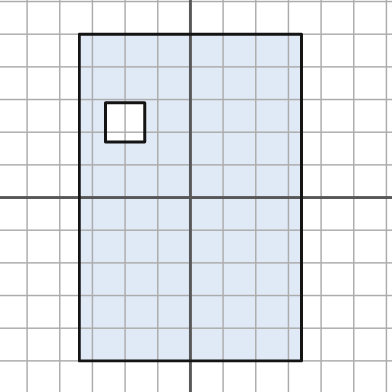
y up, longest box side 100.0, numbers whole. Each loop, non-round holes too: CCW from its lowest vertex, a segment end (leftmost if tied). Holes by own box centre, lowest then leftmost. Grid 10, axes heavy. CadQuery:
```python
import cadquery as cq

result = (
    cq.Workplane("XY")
    .moveTo(-34.0, -50.0)
    .lineTo(34.0, -50.0)
    .lineTo(34.0, 50.0)
    .lineTo(-34.0, 50.0)
    .close()
    .moveTo(-26.0, 17.0)
    .lineTo(-14.0, 17.0)
    .lineTo(-14.0, 29.0)
    .lineTo(-26.0, 29.0)
    .close()
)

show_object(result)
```